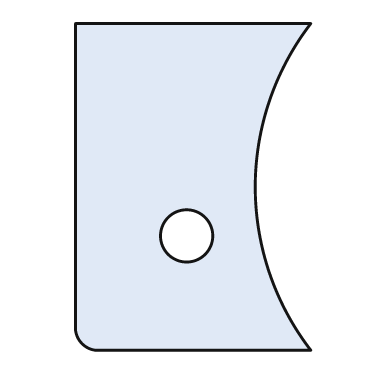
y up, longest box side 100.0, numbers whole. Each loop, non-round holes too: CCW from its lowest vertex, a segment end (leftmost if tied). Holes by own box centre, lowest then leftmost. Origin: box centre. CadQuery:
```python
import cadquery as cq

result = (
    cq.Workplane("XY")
    .moveTo(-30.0, -50.0)
    .lineTo(36.0, -50.0)
    .threePointArc((19.0, 0.0), (36.0, 50.0))
    .lineTo(-36.0, 50.0)
    .lineTo(-36.0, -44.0)
    .threePointArc((-34.0, -48.0), (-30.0, -50.0))
    .close()
    .moveTo(-2.0, -15.0)
    .circle(8.0)
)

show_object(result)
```